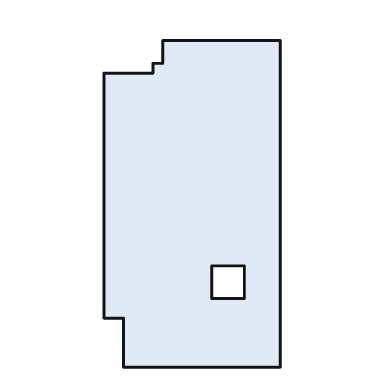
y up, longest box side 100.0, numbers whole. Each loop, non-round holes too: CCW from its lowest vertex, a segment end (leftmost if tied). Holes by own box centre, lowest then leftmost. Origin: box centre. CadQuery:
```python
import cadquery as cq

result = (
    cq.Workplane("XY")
    .moveTo(-21.0, -50.0)
    .lineTo(27.0, -50.0)
    .lineTo(27.0, 50.0)
    .lineTo(-9.0, 50.0)
    .lineTo(-9.0, 43.0)
    .lineTo(-12.0, 43.0)
    .lineTo(-12.0, 40.0)
    .lineTo(-27.0, 40.0)
    .lineTo(-27.0, -35.0)
    .lineTo(-21.0, -35.0)
    .close()
    .moveTo(6.0, -29.0)
    .lineTo(16.0, -29.0)
    .lineTo(16.0, -19.0)
    .lineTo(6.0, -19.0)
    .close()
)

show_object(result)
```